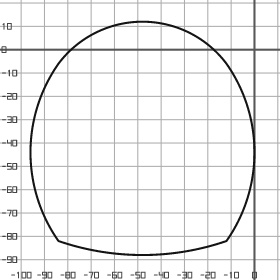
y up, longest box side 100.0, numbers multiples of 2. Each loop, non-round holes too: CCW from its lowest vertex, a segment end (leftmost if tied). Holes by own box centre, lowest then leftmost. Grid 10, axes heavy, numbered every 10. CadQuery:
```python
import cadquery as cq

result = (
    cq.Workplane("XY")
    .moveTo(-84.0, -82.0)
    .threePointArc((-48.0, -88.0), (-12.0, -82.0))
    .threePointArc((0.0, -44.0), (-12.0, -6.0))
    .threePointArc((-48.0, 12.0), (-84.0, -6.0))
    .threePointArc((-96.0, -44.0), (-84.0, -82.0))
    .close()
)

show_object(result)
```